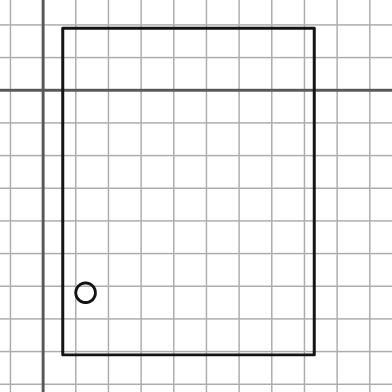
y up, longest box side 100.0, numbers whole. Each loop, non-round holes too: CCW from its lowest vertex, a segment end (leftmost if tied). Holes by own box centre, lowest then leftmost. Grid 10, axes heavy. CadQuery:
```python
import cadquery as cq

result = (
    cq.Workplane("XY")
    .moveTo(6.0, -81.0)
    .lineTo(83.0, -81.0)
    .lineTo(83.0, 19.0)
    .lineTo(6.0, 19.0)
    .close()
    .moveTo(13.0, -62.0)
    .circle(3.0)
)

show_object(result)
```